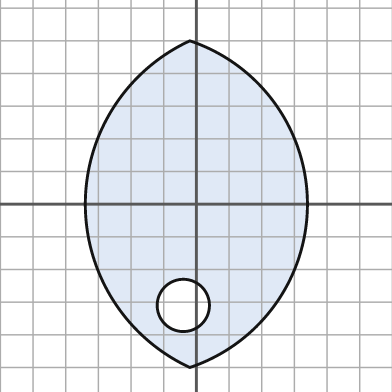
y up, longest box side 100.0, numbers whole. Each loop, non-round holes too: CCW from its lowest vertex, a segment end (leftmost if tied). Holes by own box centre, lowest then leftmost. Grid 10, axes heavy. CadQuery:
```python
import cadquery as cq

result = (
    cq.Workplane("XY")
    .moveTo(-2.0, -50.0)
    .threePointArc((34.0, 0.0), (-2.0, 50.0))
    .threePointArc((-34.0, 0.0), (-2.0, -50.0))
    .close()
    .moveTo(-4.0, -31.0)
    .circle(8.0)
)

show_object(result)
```